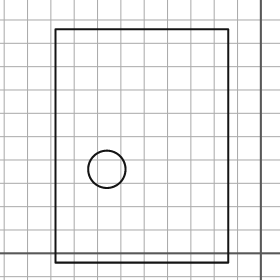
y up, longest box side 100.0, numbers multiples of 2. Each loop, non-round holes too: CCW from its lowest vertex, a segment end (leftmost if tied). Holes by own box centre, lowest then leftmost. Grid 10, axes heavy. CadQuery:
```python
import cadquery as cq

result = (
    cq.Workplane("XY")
    .moveTo(-88.0, -4.0)
    .lineTo(-14.0, -4.0)
    .lineTo(-14.0, 96.0)
    .lineTo(-88.0, 96.0)
    .close()
    .moveTo(-66.0, 36.0)
    .circle(8.0)
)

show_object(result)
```